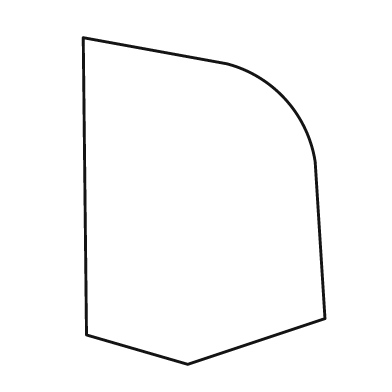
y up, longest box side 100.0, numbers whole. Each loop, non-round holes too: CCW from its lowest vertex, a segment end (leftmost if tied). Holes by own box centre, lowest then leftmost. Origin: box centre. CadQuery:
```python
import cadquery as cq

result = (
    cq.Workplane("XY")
    .moveTo(-5.0, -50.0)
    .lineTo(37.0, -36.0)
    .lineTo(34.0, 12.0)
    .threePointArc((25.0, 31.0), (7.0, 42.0))
    .lineTo(-37.0, 50.0)
    .lineTo(-36.0, -41.0)
    .close()
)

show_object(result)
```